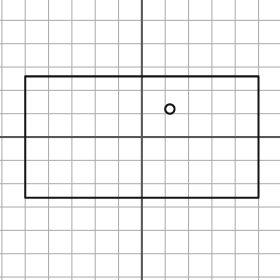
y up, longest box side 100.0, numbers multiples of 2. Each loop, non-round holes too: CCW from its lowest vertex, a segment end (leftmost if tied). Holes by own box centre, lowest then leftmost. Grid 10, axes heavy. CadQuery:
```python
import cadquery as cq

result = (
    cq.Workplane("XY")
    .moveTo(-50.0, -26.0)
    .lineTo(50.0, -26.0)
    .lineTo(50.0, 26.0)
    .lineTo(-50.0, 26.0)
    .close()
    .moveTo(12.0, 12.0)
    .circle(2.0)
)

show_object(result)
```